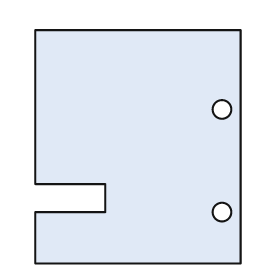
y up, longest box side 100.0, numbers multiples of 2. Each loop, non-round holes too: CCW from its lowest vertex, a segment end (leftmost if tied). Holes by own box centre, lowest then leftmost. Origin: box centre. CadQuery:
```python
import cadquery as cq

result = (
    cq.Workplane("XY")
    .moveTo(-44.0, -50.0)
    .lineTo(44.0, -50.0)
    .lineTo(44.0, 50.0)
    .lineTo(-44.0, 50.0)
    .lineTo(-44.0, -16.0)
    .lineTo(-14.0, -16.0)
    .lineTo(-14.0, -28.0)
    .lineTo(-44.0, -28.0)
    .close()
    .moveTo(36.0, -28.0)
    .circle(4.0)
    .moveTo(36.0, 16.0)
    .circle(4.0)
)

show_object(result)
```